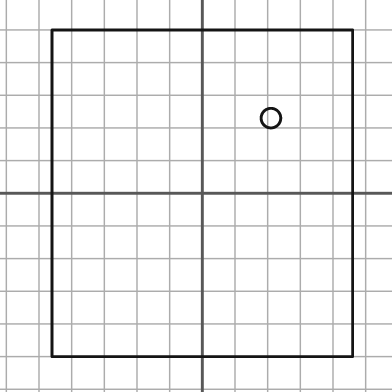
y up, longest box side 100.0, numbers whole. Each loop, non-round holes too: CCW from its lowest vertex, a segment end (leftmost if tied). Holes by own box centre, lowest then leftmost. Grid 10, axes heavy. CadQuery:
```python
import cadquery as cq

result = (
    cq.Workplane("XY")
    .moveTo(-46.0, -50.0)
    .lineTo(46.0, -50.0)
    .lineTo(46.0, 50.0)
    .lineTo(-46.0, 50.0)
    .close()
    .moveTo(21.0, 23.0)
    .circle(3.0)
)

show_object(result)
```